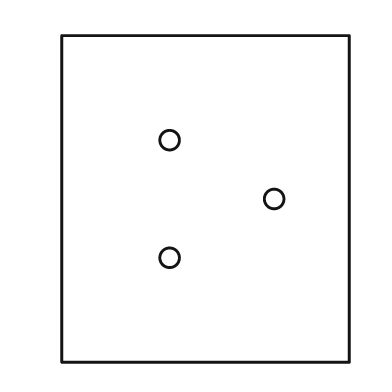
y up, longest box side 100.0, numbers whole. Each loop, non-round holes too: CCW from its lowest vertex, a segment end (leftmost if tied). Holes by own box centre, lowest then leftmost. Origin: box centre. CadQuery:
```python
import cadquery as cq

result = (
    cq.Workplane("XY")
    .moveTo(-44.0, -50.0)
    .lineTo(44.0, -50.0)
    .lineTo(44.0, 50.0)
    .lineTo(-44.0, 50.0)
    .close()
    .moveTo(-11.0, -18.0)
    .circle(3.0)
    .moveTo(21.0, 0.0)
    .circle(3.0)
    .moveTo(-11.0, 18.0)
    .circle(3.0)
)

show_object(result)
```